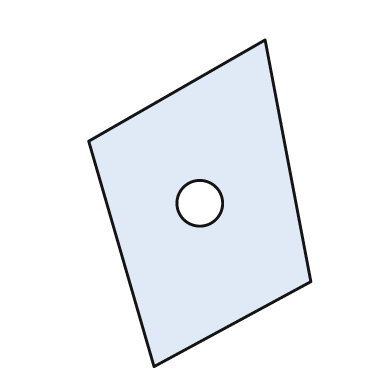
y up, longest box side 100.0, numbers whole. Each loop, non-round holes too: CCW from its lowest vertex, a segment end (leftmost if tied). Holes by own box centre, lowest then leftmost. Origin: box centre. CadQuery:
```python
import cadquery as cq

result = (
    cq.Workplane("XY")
    .moveTo(-14.0, -50.0)
    .lineTo(34.0, -24.0)
    .lineTo(20.0, 50.0)
    .lineTo(-34.0, 19.0)
    .close()
    .moveTo(0.0, 0.0)
    .circle(7.0)
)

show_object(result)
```